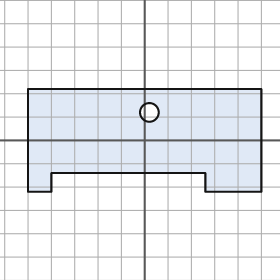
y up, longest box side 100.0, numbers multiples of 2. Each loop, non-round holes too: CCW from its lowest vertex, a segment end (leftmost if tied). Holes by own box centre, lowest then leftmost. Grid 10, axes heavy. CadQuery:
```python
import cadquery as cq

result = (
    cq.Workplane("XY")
    .moveTo(-50.0, -22.0)
    .lineTo(-40.0, -22.0)
    .lineTo(-40.0, -14.0)
    .lineTo(26.0, -14.0)
    .lineTo(26.0, -22.0)
    .lineTo(50.0, -22.0)
    .lineTo(50.0, 22.0)
    .lineTo(-50.0, 22.0)
    .close()
    .moveTo(2.0, 12.0)
    .circle(4.0)
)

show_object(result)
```